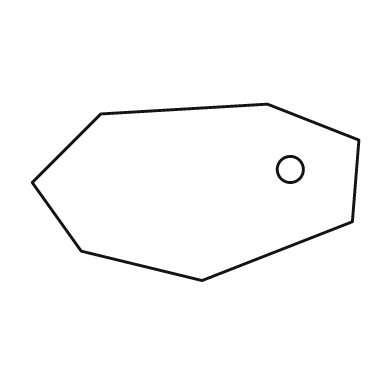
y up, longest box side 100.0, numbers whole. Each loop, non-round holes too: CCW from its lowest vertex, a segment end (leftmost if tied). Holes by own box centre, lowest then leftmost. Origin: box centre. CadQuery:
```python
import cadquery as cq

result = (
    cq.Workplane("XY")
    .moveTo(2.0, -27.0)
    .lineTo(48.0, -9.0)
    .lineTo(50.0, 16.0)
    .lineTo(22.0, 27.0)
    .lineTo(-29.0, 24.0)
    .lineTo(-50.0, 3.0)
    .lineTo(-35.0, -18.0)
    .close()
    .moveTo(29.0, 7.0)
    .circle(4.0)
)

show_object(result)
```